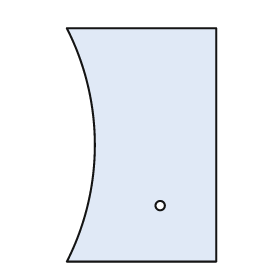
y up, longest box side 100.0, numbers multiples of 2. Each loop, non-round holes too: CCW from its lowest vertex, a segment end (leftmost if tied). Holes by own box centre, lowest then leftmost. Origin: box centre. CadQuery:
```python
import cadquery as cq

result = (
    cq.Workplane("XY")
    .moveTo(-32.0, -50.0)
    .lineTo(32.0, -50.0)
    .lineTo(32.0, 50.0)
    .lineTo(-32.0, 50.0)
    .threePointArc((-20.0, 0.0), (-32.0, -50.0))
    .close()
    .moveTo(8.0, -26.0)
    .circle(2.0)
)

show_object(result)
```